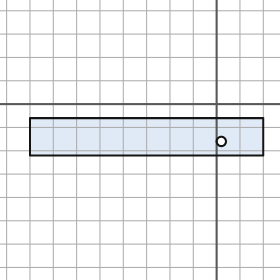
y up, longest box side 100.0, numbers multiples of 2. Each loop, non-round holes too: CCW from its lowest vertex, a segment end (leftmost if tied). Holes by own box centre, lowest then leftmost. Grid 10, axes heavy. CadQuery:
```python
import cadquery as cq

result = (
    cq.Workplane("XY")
    .moveTo(-80.0, -22.0)
    .lineTo(20.0, -22.0)
    .lineTo(20.0, -6.0)
    .lineTo(-80.0, -6.0)
    .close()
    .moveTo(2.0, -16.0)
    .circle(2.0)
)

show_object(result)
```